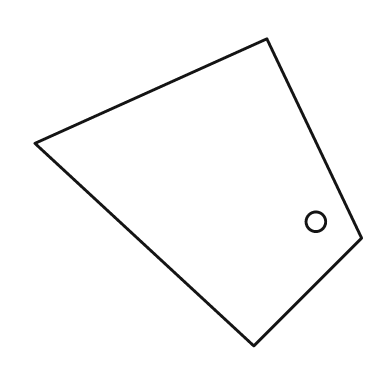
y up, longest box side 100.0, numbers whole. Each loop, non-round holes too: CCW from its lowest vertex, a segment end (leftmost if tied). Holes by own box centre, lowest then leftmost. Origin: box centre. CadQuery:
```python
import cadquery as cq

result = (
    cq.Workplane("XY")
    .moveTo(17.0, -47.0)
    .lineTo(50.0, -14.0)
    .lineTo(21.0, 47.0)
    .lineTo(-50.0, 15.0)
    .close()
    .moveTo(36.0, -9.0)
    .circle(3.0)
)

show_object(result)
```